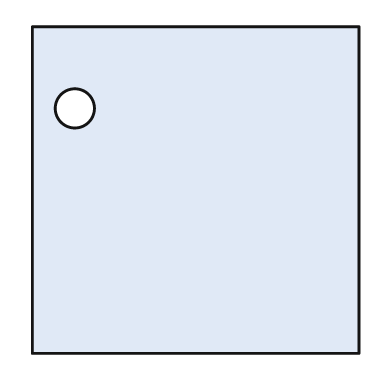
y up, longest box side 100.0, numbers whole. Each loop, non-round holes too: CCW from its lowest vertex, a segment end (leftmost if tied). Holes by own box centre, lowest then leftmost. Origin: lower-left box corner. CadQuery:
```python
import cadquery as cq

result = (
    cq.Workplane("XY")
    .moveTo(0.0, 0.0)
    .lineTo(100.0, 0.0)
    .lineTo(100.0, 100.0)
    .lineTo(0.0, 100.0)
    .close()
    .moveTo(13.0, 75.0)
    .circle(6.0)
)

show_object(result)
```